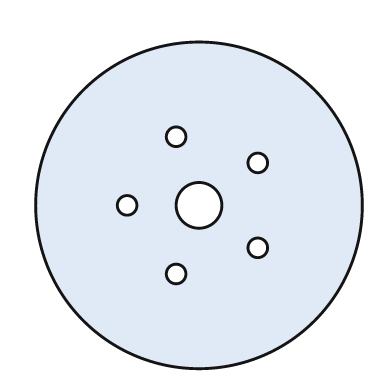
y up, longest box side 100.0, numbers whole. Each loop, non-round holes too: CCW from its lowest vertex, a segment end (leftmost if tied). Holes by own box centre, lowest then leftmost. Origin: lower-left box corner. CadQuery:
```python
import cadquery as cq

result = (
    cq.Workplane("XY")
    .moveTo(50.0, 50.0)
    .circle(50.0)
    .moveTo(43.0, 29.0)
    .circle(3.0)
    .moveTo(68.0, 37.0)
    .circle(3.0)
    .moveTo(28.0, 50.0)
    .circle(3.0)
    .moveTo(50.0, 50.0)
    .circle(7.0)
    .moveTo(68.0, 63.0)
    .circle(3.0)
    .moveTo(43.0, 71.0)
    .circle(3.0)
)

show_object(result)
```